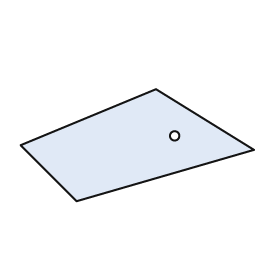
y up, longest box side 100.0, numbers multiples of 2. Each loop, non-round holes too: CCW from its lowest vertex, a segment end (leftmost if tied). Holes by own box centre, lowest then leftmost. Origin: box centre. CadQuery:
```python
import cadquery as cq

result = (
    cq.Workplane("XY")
    .moveTo(-26.0, -24.0)
    .lineTo(50.0, -2.0)
    .lineTo(8.0, 24.0)
    .lineTo(-50.0, 0.0)
    .close()
    .moveTo(16.0, 4.0)
    .circle(2.0)
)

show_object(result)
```